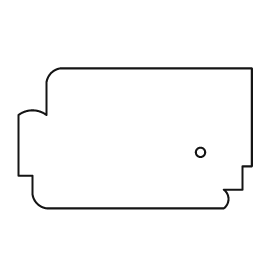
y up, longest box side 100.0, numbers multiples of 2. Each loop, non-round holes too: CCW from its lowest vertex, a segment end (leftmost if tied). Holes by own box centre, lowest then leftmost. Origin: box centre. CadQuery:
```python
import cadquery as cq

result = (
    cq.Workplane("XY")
    .moveTo(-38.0, -30.0)
    .lineTo(38.0, -30.0)
    .threePointArc((40.0, -26.0), (38.0, -22.0))
    .lineTo(46.0, -22.0)
    .lineTo(46.0, -12.0)
    .lineTo(50.0, -12.0)
    .lineTo(50.0, 30.0)
    .lineTo(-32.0, 30.0)
    .threePointArc((-36.0, 28.0), (-38.0, 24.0))
    .lineTo(-38.0, 10.0)
    .threePointArc((-44.0, 12.0), (-50.0, 10.0))
    .lineTo(-50.0, -16.0)
    .lineTo(-44.0, -16.0)
    .lineTo(-44.0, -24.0)
    .threePointArc((-42.0, -28.0), (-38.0, -30.0))
    .close()
    .moveTo(28.0, -6.0)
    .circle(2.0)
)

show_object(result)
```